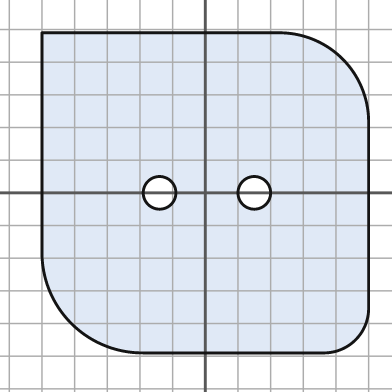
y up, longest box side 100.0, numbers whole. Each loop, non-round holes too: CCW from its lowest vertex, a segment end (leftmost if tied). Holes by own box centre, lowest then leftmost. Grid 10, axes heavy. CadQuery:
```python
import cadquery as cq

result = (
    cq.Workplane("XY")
    .moveTo(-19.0, -49.0)
    .lineTo(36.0, -49.0)
    .threePointArc((46.0, -45.0), (50.0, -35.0))
    .lineTo(50.0, 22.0)
    .threePointArc((42.0, 41.0), (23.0, 49.0))
    .lineTo(-50.0, 49.0)
    .lineTo(-50.0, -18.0)
    .threePointArc((-41.0, -40.0), (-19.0, -49.0))
    .close()
    .moveTo(-14.0, 0.0)
    .circle(5.0)
    .moveTo(15.0, 0.0)
    .circle(5.0)
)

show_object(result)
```